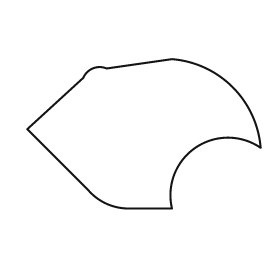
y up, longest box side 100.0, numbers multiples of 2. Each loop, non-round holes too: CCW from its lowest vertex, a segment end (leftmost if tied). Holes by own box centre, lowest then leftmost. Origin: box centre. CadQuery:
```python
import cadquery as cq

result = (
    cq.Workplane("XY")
    .moveTo(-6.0, -32.0)
    .lineTo(12.0, -32.0)
    .threePointArc((22.0, -6.0), (50.0, -6.0))
    .threePointArc((38.0, 20.0), (12.0, 32.0))
    .lineTo(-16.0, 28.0)
    .threePointArc((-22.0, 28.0), (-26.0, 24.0))
    .lineTo(-50.0, 2.0)
    .lineTo(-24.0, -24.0)
    .threePointArc((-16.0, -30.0), (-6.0, -32.0))
    .close()
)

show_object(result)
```